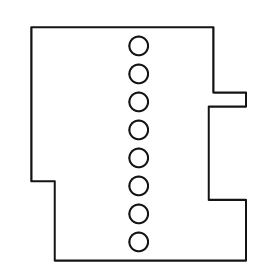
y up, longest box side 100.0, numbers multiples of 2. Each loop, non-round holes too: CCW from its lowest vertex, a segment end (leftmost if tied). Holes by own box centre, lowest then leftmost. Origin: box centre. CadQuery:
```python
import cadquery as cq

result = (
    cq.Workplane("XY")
    .moveTo(-36.0, -50.0)
    .lineTo(46.0, -50.0)
    .lineTo(46.0, -24.0)
    .lineTo(30.0, -24.0)
    .lineTo(30.0, 16.0)
    .lineTo(46.0, 16.0)
    .lineTo(46.0, 22.0)
    .lineTo(32.0, 22.0)
    .lineTo(32.0, 50.0)
    .lineTo(-46.0, 50.0)
    .lineTo(-46.0, -16.0)
    .lineTo(-36.0, -16.0)
    .close()
    .moveTo(0.0, -42.0)
    .circle(4.0)
    .moveTo(0.0, -30.0)
    .circle(4.0)
    .moveTo(0.0, -18.0)
    .circle(4.0)
    .moveTo(0.0, -6.0)
    .circle(4.0)
    .moveTo(0.0, 6.0)
    .circle(4.0)
    .moveTo(0.0, 18.0)
    .circle(4.0)
    .moveTo(0.0, 30.0)
    .circle(4.0)
    .moveTo(0.0, 42.0)
    .circle(4.0)
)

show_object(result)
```